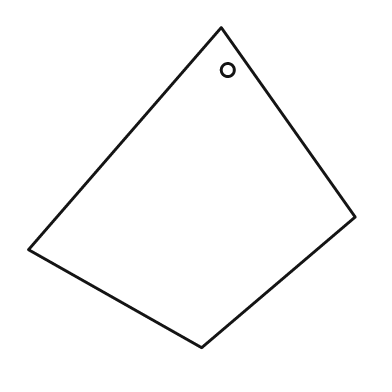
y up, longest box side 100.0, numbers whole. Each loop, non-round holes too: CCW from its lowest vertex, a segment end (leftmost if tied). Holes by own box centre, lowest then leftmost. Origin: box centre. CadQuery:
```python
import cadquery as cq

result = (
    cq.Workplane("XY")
    .moveTo(3.0, -49.0)
    .lineTo(50.0, -9.0)
    .lineTo(9.0, 49.0)
    .lineTo(-50.0, -19.0)
    .close()
    .moveTo(11.0, 36.0)
    .circle(2.0)
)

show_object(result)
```